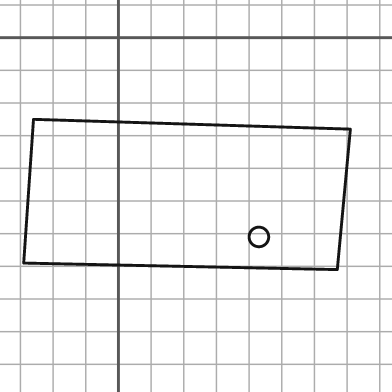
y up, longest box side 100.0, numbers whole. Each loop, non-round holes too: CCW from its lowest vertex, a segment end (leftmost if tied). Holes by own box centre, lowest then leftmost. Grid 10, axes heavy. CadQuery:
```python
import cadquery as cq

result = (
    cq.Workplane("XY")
    .moveTo(67.0, -71.0)
    .lineTo(71.0, -28.0)
    .lineTo(-26.0, -25.0)
    .lineTo(-29.0, -69.0)
    .close()
    .moveTo(43.0, -61.0)
    .circle(3.0)
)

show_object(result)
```